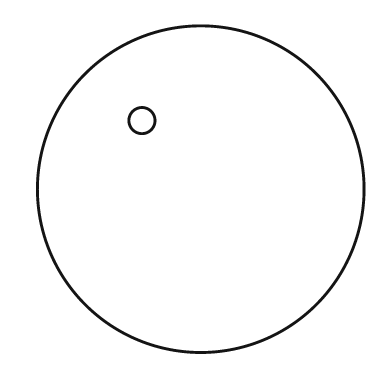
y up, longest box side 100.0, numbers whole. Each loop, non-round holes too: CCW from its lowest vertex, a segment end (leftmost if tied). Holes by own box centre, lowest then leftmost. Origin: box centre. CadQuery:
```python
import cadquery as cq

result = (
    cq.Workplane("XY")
    .moveTo(0.0, 0.0)
    .circle(50.0)
    .moveTo(-18.0, 21.0)
    .circle(4.0)
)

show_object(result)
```